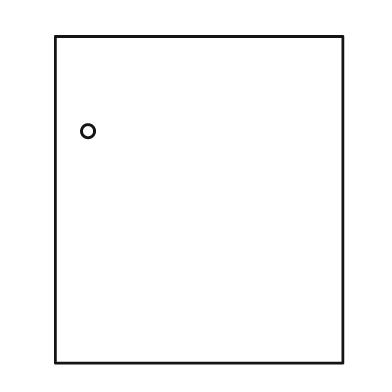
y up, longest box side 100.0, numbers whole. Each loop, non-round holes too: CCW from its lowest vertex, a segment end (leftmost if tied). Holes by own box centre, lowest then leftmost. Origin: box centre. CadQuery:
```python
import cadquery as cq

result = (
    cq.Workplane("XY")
    .moveTo(-44.0, -50.0)
    .lineTo(44.0, -50.0)
    .lineTo(44.0, 50.0)
    .lineTo(-44.0, 50.0)
    .close()
    .moveTo(-34.0, 21.0)
    .circle(2.0)
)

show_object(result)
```